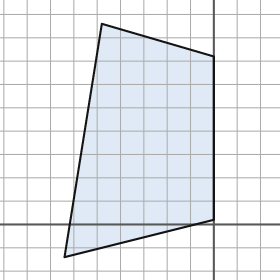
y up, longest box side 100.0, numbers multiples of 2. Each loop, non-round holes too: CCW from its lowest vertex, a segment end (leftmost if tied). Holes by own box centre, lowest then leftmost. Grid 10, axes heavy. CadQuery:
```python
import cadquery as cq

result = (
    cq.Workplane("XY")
    .moveTo(-64.0, -14.0)
    .lineTo(0.0, 2.0)
    .lineTo(0.0, 72.0)
    .lineTo(-48.0, 86.0)
    .close()
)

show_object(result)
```